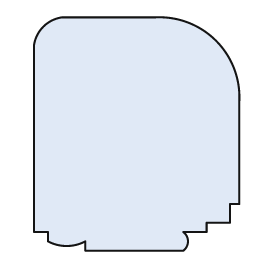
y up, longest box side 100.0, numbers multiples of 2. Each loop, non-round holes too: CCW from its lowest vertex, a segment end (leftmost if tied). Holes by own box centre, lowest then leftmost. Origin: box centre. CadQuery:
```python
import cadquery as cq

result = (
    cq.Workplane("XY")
    .moveTo(-22.0, -50.0)
    .lineTo(20.0, -50.0)
    .threePointArc((22.0, -46.0), (20.0, -42.0))
    .lineTo(30.0, -42.0)
    .lineTo(30.0, -38.0)
    .lineTo(40.0, -38.0)
    .lineTo(40.0, -30.0)
    .lineTo(44.0, -30.0)
    .lineTo(44.0, 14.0)
    .threePointArc((34.0, 40.0), (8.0, 50.0))
    .lineTo(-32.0, 50.0)
    .threePointArc((-40.0, 46.0), (-44.0, 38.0))
    .lineTo(-44.0, -42.0)
    .lineTo(-38.0, -42.0)
    .lineTo(-38.0, -46.0)
    .threePointArc((-30.0, -48.0), (-22.0, -46.0))
    .close()
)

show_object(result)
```